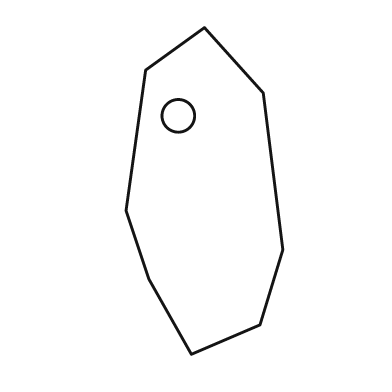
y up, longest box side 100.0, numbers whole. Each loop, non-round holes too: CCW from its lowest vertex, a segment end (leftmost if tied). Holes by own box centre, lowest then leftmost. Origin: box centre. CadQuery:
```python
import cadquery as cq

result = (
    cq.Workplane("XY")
    .moveTo(-4.0, -50.0)
    .lineTo(17.0, -41.0)
    .lineTo(24.0, -18.0)
    .lineTo(18.0, 30.0)
    .lineTo(0.0, 50.0)
    .lineTo(-18.0, 37.0)
    .lineTo(-24.0, -6.0)
    .lineTo(-17.0, -27.0)
    .close()
    .moveTo(-8.0, 23.0)
    .circle(5.0)
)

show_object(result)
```